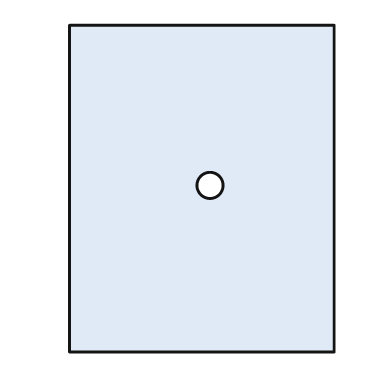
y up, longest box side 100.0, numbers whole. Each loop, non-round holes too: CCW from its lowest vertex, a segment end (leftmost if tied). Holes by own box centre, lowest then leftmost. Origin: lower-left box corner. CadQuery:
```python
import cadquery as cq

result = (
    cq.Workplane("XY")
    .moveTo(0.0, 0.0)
    .lineTo(81.0, 0.0)
    .lineTo(81.0, 100.0)
    .lineTo(0.0, 100.0)
    .close()
    .moveTo(43.0, 51.0)
    .circle(4.0)
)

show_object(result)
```